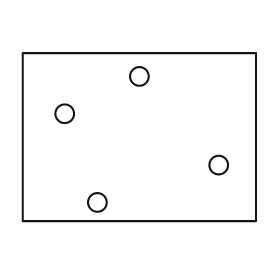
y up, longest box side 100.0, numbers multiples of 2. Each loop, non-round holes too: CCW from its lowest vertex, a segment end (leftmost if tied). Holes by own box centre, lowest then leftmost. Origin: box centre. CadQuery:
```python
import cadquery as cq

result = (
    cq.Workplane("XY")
    .moveTo(-50.0, -36.0)
    .lineTo(50.0, -36.0)
    .lineTo(50.0, 36.0)
    .lineTo(-50.0, 36.0)
    .close()
    .moveTo(-18.0, -28.0)
    .circle(4.0)
    .moveTo(34.0, -12.0)
    .circle(4.0)
    .moveTo(-32.0, 10.0)
    .circle(4.0)
    .moveTo(0.0, 26.0)
    .circle(4.0)
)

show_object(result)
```